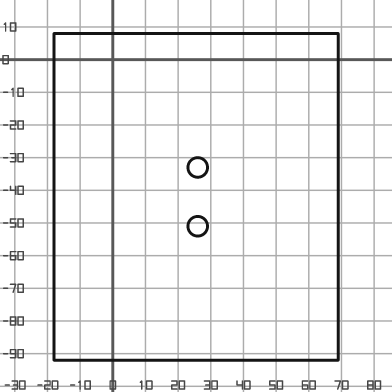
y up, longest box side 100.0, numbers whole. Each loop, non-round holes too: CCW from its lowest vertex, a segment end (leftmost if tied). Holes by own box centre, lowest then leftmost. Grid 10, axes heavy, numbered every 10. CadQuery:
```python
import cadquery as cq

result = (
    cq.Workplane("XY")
    .moveTo(-18.0, -92.0)
    .lineTo(69.0, -92.0)
    .lineTo(69.0, 8.0)
    .lineTo(-18.0, 8.0)
    .close()
    .moveTo(26.0, -51.0)
    .circle(3.0)
    .moveTo(26.0, -33.0)
    .circle(3.0)
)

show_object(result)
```